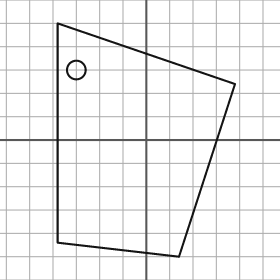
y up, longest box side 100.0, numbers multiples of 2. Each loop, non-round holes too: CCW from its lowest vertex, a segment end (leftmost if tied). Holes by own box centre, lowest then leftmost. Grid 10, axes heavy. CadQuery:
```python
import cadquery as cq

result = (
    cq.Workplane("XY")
    .moveTo(14.0, -50.0)
    .lineTo(38.0, 24.0)
    .lineTo(-38.0, 50.0)
    .lineTo(-38.0, -44.0)
    .close()
    .moveTo(-30.0, 30.0)
    .circle(4.0)
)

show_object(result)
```